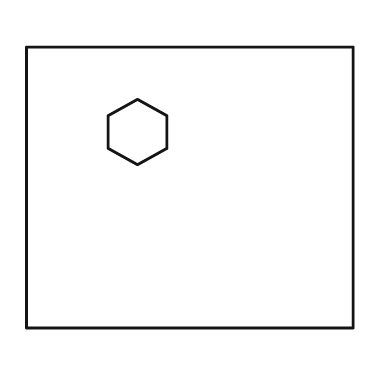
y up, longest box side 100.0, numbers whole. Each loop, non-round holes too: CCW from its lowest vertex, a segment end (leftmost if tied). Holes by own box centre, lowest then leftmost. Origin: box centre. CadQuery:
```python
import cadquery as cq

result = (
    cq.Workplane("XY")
    .moveTo(-50.0, -43.0)
    .lineTo(50.0, -43.0)
    .lineTo(50.0, 43.0)
    .lineTo(-50.0, 43.0)
    .close()
    .moveTo(-16.0, 7.0)
    .lineTo(-7.0, 12.0)
    .lineTo(-7.0, 22.0)
    .lineTo(-16.0, 27.0)
    .lineTo(-25.0, 22.0)
    .lineTo(-25.0, 12.0)
    .close()
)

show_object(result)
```